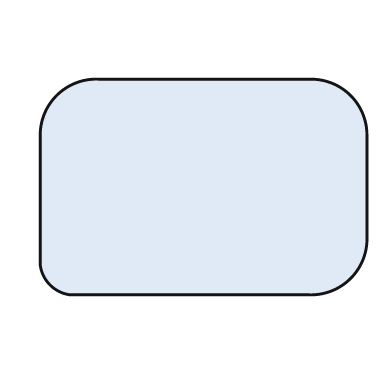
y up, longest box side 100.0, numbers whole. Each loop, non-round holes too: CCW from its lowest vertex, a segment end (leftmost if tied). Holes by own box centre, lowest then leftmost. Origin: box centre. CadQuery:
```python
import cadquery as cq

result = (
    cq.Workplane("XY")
    .moveTo(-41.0, -33.0)
    .lineTo(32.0, -33.0)
    .threePointArc((45.0, -28.0), (50.0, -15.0))
    .lineTo(50.0, 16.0)
    .threePointArc((45.0, 28.0), (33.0, 33.0))
    .lineTo(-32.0, 33.0)
    .threePointArc((-45.0, 28.0), (-50.0, 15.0))
    .lineTo(-50.0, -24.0)
    .threePointArc((-47.0, -30.0), (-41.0, -33.0))
    .close()
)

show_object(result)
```